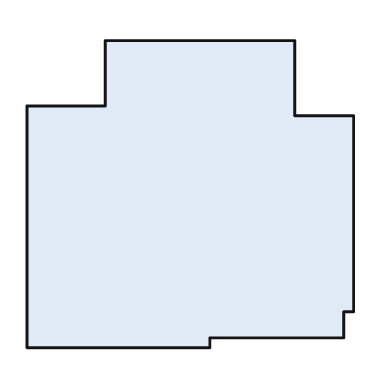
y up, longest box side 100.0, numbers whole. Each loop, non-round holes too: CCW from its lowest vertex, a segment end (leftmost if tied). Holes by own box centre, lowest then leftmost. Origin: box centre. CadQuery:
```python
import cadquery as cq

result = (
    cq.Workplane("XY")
    .moveTo(-50.0, -47.0)
    .lineTo(6.0, -47.0)
    .lineTo(6.0, -44.0)
    .lineTo(47.0, -44.0)
    .lineTo(47.0, -36.0)
    .lineTo(50.0, -36.0)
    .lineTo(50.0, 24.0)
    .lineTo(32.0, 24.0)
    .lineTo(32.0, 47.0)
    .lineTo(-26.0, 47.0)
    .lineTo(-26.0, 27.0)
    .lineTo(-50.0, 27.0)
    .close()
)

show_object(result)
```